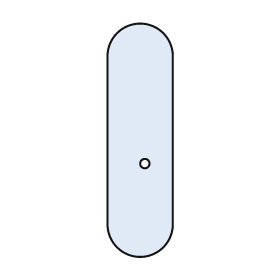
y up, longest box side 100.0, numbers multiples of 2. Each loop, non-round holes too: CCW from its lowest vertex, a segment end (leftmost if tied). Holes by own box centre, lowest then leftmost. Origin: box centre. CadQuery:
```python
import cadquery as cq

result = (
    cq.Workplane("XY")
    .moveTo(-14.0, -36.0)
    .threePointArc((0.0, -50.0), (14.0, -36.0))
    .lineTo(14.0, 36.0)
    .threePointArc((0.0, 50.0), (-14.0, 36.0))
    .close()
    .moveTo(2.0, -10.0)
    .circle(2.0)
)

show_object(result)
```